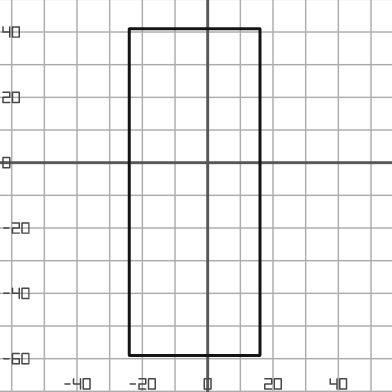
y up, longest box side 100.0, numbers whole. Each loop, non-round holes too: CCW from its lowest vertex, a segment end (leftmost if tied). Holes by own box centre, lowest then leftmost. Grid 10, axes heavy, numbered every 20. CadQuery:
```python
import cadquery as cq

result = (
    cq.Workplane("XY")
    .moveTo(-24.0, -59.0)
    .lineTo(16.0, -59.0)
    .lineTo(16.0, 41.0)
    .lineTo(-24.0, 41.0)
    .close()
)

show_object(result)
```